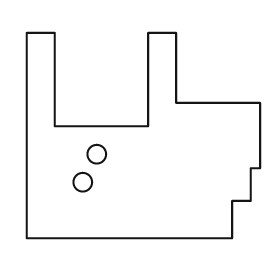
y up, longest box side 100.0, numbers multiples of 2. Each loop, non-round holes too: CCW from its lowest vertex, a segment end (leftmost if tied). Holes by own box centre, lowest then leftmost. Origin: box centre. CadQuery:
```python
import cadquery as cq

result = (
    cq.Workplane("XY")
    .moveTo(-50.0, -44.0)
    .lineTo(38.0, -44.0)
    .lineTo(38.0, -28.0)
    .lineTo(46.0, -28.0)
    .lineTo(46.0, -14.0)
    .lineTo(50.0, -14.0)
    .lineTo(50.0, 14.0)
    .lineTo(14.0, 14.0)
    .lineTo(14.0, 44.0)
    .lineTo(2.0, 44.0)
    .lineTo(2.0, 4.0)
    .lineTo(-38.0, 4.0)
    .lineTo(-38.0, 44.0)
    .lineTo(-50.0, 44.0)
    .close()
    .moveTo(-26.0, -20.0)
    .circle(4.0)
    .moveTo(-20.0, -8.0)
    .circle(4.0)
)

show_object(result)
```